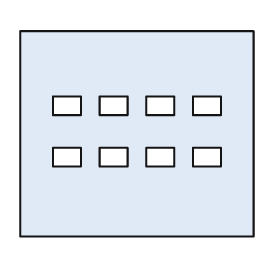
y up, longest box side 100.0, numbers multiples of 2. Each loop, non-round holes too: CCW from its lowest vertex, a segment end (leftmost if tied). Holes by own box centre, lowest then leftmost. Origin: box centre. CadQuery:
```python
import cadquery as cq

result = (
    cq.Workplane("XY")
    .moveTo(-50.0, -44.0)
    .lineTo(50.0, -44.0)
    .lineTo(50.0, 44.0)
    .lineTo(-50.0, 44.0)
    .close()
    .moveTo(-36.0, -14.0)
    .lineTo(-24.0, -14.0)
    .lineTo(-24.0, -6.0)
    .lineTo(-36.0, -6.0)
    .close()
    .moveTo(-16.0, -14.0)
    .lineTo(-4.0, -14.0)
    .lineTo(-4.0, -6.0)
    .lineTo(-16.0, -6.0)
    .close()
    .moveTo(4.0, -14.0)
    .lineTo(16.0, -14.0)
    .lineTo(16.0, -6.0)
    .lineTo(4.0, -6.0)
    .close()
    .moveTo(24.0, -14.0)
    .lineTo(36.0, -14.0)
    .lineTo(36.0, -6.0)
    .lineTo(24.0, -6.0)
    .close()
    .moveTo(-36.0, 8.0)
    .lineTo(-24.0, 8.0)
    .lineTo(-24.0, 16.0)
    .lineTo(-36.0, 16.0)
    .close()
    .moveTo(-16.0, 8.0)
    .lineTo(-4.0, 8.0)
    .lineTo(-4.0, 16.0)
    .lineTo(-16.0, 16.0)
    .close()
    .moveTo(4.0, 8.0)
    .lineTo(16.0, 8.0)
    .lineTo(16.0, 16.0)
    .lineTo(4.0, 16.0)
    .close()
    .moveTo(24.0, 8.0)
    .lineTo(36.0, 8.0)
    .lineTo(36.0, 16.0)
    .lineTo(24.0, 16.0)
    .close()
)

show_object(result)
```